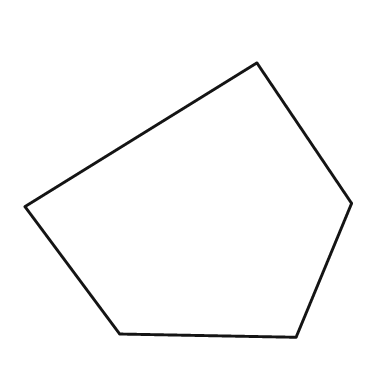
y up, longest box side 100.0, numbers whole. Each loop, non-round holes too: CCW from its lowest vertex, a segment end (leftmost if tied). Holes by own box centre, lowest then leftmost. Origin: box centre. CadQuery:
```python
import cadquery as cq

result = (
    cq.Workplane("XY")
    .moveTo(33.0, -42.0)
    .lineTo(50.0, -1.0)
    .lineTo(21.0, 42.0)
    .lineTo(-50.0, -2.0)
    .lineTo(-21.0, -41.0)
    .close()
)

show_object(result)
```